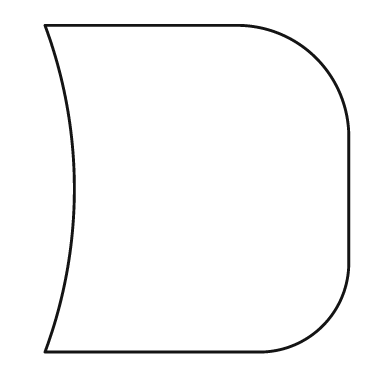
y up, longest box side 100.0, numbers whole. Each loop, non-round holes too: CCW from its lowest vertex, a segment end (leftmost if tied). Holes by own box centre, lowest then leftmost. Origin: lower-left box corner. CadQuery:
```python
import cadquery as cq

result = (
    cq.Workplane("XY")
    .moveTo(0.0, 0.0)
    .lineTo(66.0, 0.0)
    .threePointArc((85.0, 8.0), (93.0, 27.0))
    .lineTo(93.0, 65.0)
    .threePointArc((83.0, 90.0), (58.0, 100.0))
    .lineTo(0.0, 100.0)
    .threePointArc((9.0, 50.0), (0.0, 0.0))
    .close()
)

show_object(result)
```